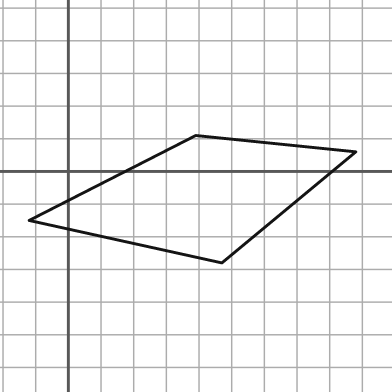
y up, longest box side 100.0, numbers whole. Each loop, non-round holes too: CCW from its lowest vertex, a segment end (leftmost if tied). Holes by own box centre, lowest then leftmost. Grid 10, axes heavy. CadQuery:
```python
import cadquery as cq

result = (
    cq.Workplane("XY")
    .moveTo(47.0, -28.0)
    .lineTo(88.0, 6.0)
    .lineTo(39.0, 11.0)
    .lineTo(-12.0, -15.0)
    .close()
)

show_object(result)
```